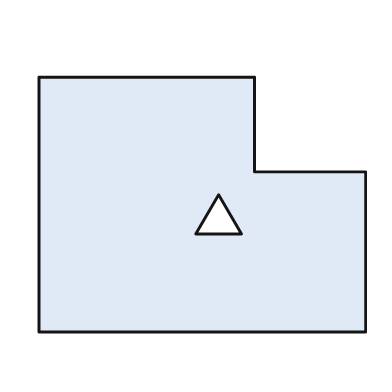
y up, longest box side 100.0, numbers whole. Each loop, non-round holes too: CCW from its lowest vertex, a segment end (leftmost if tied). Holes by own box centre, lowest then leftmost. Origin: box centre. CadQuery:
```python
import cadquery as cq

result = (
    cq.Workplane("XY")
    .moveTo(-50.0, -39.0)
    .lineTo(50.0, -39.0)
    .lineTo(50.0, 10.0)
    .lineTo(16.0, 10.0)
    .lineTo(16.0, 39.0)
    .lineTo(-50.0, 39.0)
    .close()
    .moveTo(-2.0, -9.0)
    .lineTo(12.0, -9.0)
    .lineTo(5.0, 3.0)
    .close()
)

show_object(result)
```